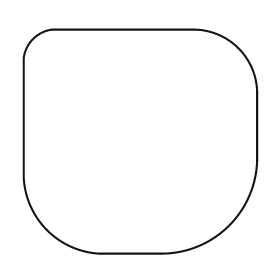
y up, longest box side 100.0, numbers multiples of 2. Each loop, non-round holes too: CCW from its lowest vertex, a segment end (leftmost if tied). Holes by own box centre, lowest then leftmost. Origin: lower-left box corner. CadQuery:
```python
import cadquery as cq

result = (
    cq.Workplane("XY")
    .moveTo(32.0, 0.0)
    .lineTo(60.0, 0.0)
    .threePointArc((88.0, 12.0), (100.0, 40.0))
    .lineTo(100.0, 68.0)
    .threePointArc((92.0, 88.0), (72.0, 96.0))
    .lineTo(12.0, 96.0)
    .threePointArc((4.0, 92.0), (0.0, 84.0))
    .lineTo(0.0, 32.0)
    .threePointArc((10.0, 10.0), (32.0, 0.0))
    .close()
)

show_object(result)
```